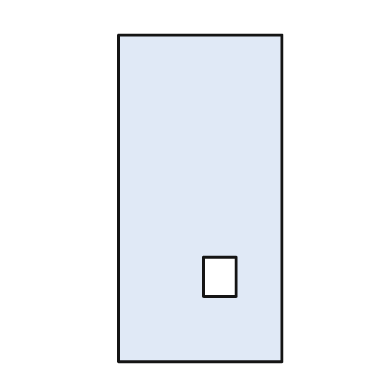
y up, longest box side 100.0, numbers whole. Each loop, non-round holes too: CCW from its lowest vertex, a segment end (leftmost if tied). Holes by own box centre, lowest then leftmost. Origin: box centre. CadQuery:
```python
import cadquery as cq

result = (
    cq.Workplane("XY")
    .moveTo(-25.0, -50.0)
    .lineTo(25.0, -50.0)
    .lineTo(25.0, 50.0)
    .lineTo(-25.0, 50.0)
    .close()
    .moveTo(1.0, -30.0)
    .lineTo(11.0, -30.0)
    .lineTo(11.0, -18.0)
    .lineTo(1.0, -18.0)
    .close()
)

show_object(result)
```